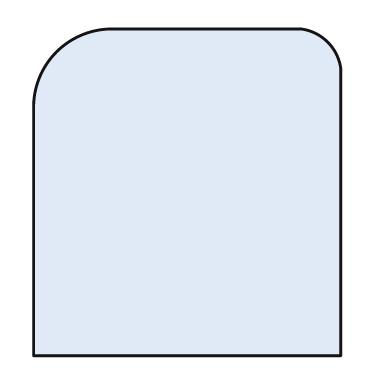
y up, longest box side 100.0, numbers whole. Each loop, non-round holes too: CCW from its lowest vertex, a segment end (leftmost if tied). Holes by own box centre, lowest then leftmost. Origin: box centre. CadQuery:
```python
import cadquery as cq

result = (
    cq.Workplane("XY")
    .moveTo(-47.0, -50.0)
    .lineTo(47.0, -50.0)
    .lineTo(47.0, 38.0)
    .threePointArc((43.0, 46.0), (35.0, 50.0))
    .lineTo(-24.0, 50.0)
    .threePointArc((-40.0, 43.0), (-47.0, 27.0))
    .close()
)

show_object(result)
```